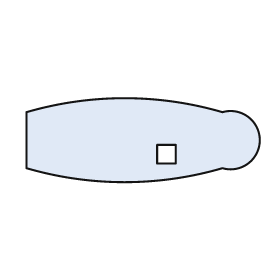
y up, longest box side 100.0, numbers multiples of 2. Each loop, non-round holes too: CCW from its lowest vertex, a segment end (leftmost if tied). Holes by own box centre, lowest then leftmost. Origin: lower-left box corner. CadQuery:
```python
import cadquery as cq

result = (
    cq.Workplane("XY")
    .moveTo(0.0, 6.0)
    .threePointArc((42.0, 0.0), (84.0, 6.0))
    .threePointArc((100.0, 18.0), (84.0, 30.0))
    .threePointArc((42.0, 36.0), (0.0, 30.0))
    .close()
    .moveTo(56.0, 8.0)
    .lineTo(64.0, 8.0)
    .lineTo(64.0, 16.0)
    .lineTo(56.0, 16.0)
    .close()
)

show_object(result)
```